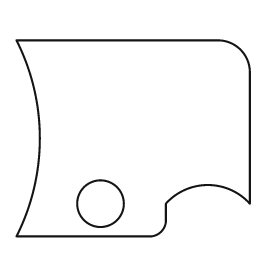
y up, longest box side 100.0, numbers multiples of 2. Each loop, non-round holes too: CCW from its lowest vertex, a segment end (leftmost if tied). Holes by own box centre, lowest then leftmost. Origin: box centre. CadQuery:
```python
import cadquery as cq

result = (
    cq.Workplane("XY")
    .moveTo(-50.0, -42.0)
    .lineTo(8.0, -42.0)
    .threePointArc((12.0, -40.0), (14.0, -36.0))
    .lineTo(14.0, -28.0)
    .threePointArc((32.0, -20.0), (50.0, -28.0))
    .lineTo(50.0, 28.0)
    .threePointArc((46.0, 38.0), (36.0, 42.0))
    .lineTo(-50.0, 42.0)
    .threePointArc((-40.0, 0.0), (-50.0, -42.0))
    .close()
    .moveTo(-14.0, -28.0)
    .circle(10.0)
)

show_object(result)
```